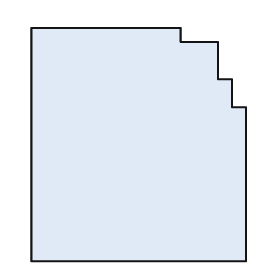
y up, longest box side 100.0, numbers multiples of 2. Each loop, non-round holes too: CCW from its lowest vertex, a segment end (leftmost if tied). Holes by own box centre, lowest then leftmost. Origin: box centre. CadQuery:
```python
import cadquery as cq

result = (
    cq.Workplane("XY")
    .moveTo(-46.0, -50.0)
    .lineTo(46.0, -50.0)
    .lineTo(46.0, 16.0)
    .lineTo(40.0, 16.0)
    .lineTo(40.0, 28.0)
    .lineTo(34.0, 28.0)
    .lineTo(34.0, 44.0)
    .lineTo(18.0, 44.0)
    .lineTo(18.0, 50.0)
    .lineTo(-46.0, 50.0)
    .close()
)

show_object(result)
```